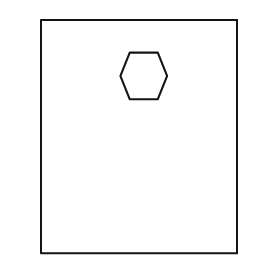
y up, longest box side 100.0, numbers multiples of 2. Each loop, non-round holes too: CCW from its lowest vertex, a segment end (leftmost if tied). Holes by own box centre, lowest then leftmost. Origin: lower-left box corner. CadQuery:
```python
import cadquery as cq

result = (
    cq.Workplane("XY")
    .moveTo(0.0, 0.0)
    .lineTo(84.0, 0.0)
    .lineTo(84.0, 100.0)
    .lineTo(0.0, 100.0)
    .close()
    .moveTo(38.0, 66.0)
    .lineTo(50.0, 66.0)
    .lineTo(54.0, 76.0)
    .lineTo(50.0, 86.0)
    .lineTo(38.0, 86.0)
    .lineTo(34.0, 76.0)
    .close()
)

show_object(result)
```